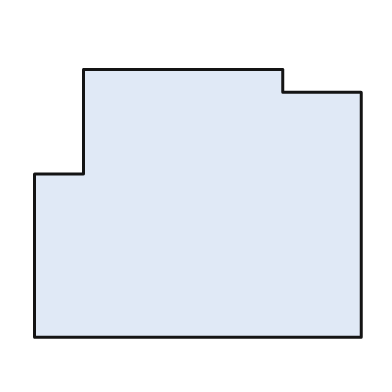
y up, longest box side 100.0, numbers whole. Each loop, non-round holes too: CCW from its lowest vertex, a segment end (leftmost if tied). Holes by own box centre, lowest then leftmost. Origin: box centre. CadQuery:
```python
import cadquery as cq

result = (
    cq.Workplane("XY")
    .moveTo(-50.0, -41.0)
    .lineTo(50.0, -41.0)
    .lineTo(50.0, 34.0)
    .lineTo(26.0, 34.0)
    .lineTo(26.0, 41.0)
    .lineTo(-35.0, 41.0)
    .lineTo(-35.0, 9.0)
    .lineTo(-50.0, 9.0)
    .close()
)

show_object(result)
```